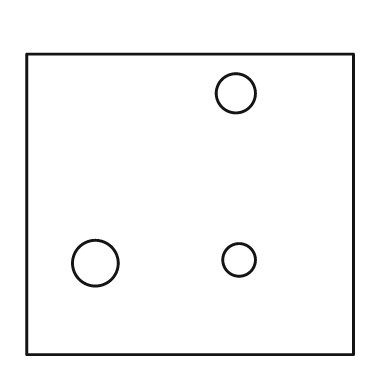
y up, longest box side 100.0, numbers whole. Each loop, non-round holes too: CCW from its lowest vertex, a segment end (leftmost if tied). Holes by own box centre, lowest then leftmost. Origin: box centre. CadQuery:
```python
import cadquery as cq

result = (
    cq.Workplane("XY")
    .moveTo(-50.0, -46.0)
    .lineTo(50.0, -46.0)
    .lineTo(50.0, 46.0)
    .lineTo(-50.0, 46.0)
    .close()
    .moveTo(-29.0, -18.0)
    .circle(7.0)
    .moveTo(15.0, -17.0)
    .circle(5.0)
    .moveTo(14.0, 34.0)
    .circle(6.0)
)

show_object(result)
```